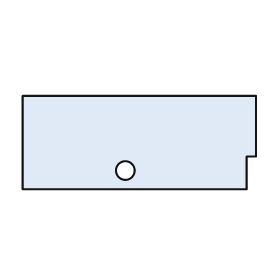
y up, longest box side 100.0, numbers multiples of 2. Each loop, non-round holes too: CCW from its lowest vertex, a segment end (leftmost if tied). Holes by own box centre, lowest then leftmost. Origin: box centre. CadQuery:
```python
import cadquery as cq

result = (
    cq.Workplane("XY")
    .moveTo(-50.0, -20.0)
    .lineTo(46.0, -20.0)
    .lineTo(46.0, -6.0)
    .lineTo(50.0, -6.0)
    .lineTo(50.0, 20.0)
    .lineTo(-50.0, 20.0)
    .close()
    .moveTo(-6.0, -12.0)
    .circle(4.0)
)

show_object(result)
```